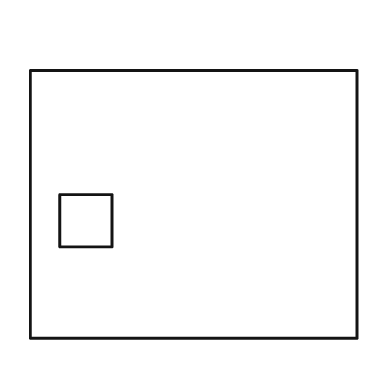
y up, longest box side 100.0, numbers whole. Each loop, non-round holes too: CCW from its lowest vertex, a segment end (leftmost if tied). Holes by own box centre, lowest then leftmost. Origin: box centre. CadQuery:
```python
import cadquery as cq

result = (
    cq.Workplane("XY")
    .moveTo(-50.0, -41.0)
    .lineTo(50.0, -41.0)
    .lineTo(50.0, 41.0)
    .lineTo(-50.0, 41.0)
    .close()
    .moveTo(-41.0, -13.0)
    .lineTo(-25.0, -13.0)
    .lineTo(-25.0, 3.0)
    .lineTo(-41.0, 3.0)
    .close()
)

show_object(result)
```